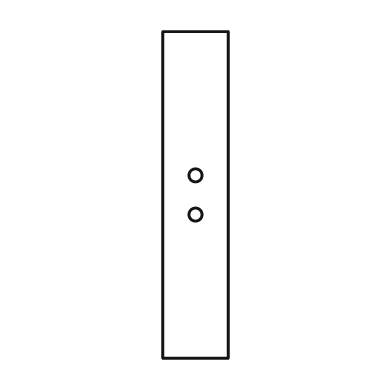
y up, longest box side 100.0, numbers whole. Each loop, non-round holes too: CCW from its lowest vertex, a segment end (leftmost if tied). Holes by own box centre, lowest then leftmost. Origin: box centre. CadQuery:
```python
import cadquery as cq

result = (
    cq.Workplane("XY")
    .moveTo(-10.0, -50.0)
    .lineTo(10.0, -50.0)
    .lineTo(10.0, 50.0)
    .lineTo(-10.0, 50.0)
    .close()
    .moveTo(0.0, -6.0)
    .circle(2.0)
    .moveTo(0.0, 6.0)
    .circle(2.0)
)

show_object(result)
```